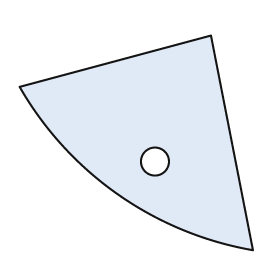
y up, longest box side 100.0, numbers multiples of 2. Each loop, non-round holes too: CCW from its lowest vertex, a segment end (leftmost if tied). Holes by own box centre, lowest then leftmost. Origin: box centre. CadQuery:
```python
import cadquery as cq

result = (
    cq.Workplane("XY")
    .moveTo(50.0, -46.0)
    .lineTo(32.0, 46.0)
    .lineTo(-50.0, 24.0)
    .threePointArc((-8.0, -22.0), (50.0, -46.0))
    .close()
    .moveTo(8.0, -8.0)
    .circle(6.0)
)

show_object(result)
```